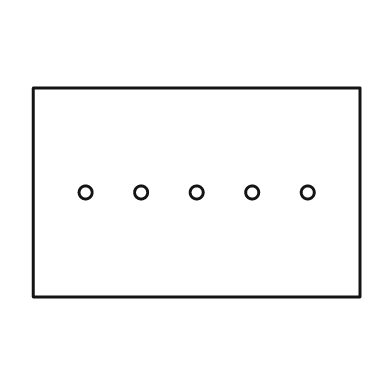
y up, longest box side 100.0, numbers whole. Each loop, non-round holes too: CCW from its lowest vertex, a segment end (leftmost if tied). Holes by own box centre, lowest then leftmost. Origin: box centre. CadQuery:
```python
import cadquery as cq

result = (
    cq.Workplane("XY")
    .moveTo(-50.0, -32.0)
    .lineTo(50.0, -32.0)
    .lineTo(50.0, 32.0)
    .lineTo(-50.0, 32.0)
    .close()
    .moveTo(-34.0, 0.0)
    .circle(2.0)
    .moveTo(-17.0, 0.0)
    .circle(2.0)
    .moveTo(0.0, 0.0)
    .circle(2.0)
    .moveTo(17.0, 0.0)
    .circle(2.0)
    .moveTo(34.0, 0.0)
    .circle(2.0)
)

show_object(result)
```